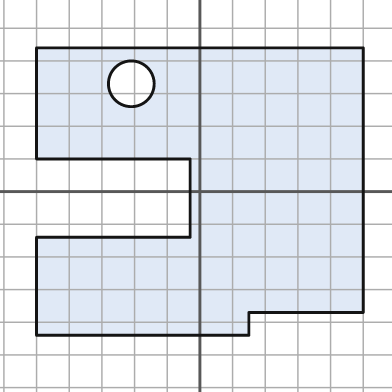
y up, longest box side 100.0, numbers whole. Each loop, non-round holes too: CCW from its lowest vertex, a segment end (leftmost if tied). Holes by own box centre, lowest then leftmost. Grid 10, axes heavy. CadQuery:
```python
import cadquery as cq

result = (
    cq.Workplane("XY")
    .moveTo(-50.0, -44.0)
    .lineTo(15.0, -44.0)
    .lineTo(15.0, -37.0)
    .lineTo(50.0, -37.0)
    .lineTo(50.0, 44.0)
    .lineTo(-50.0, 44.0)
    .lineTo(-50.0, 10.0)
    .lineTo(-3.0, 10.0)
    .lineTo(-3.0, -14.0)
    .lineTo(-50.0, -14.0)
    .close()
    .moveTo(-21.0, 33.0)
    .circle(7.0)
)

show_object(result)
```